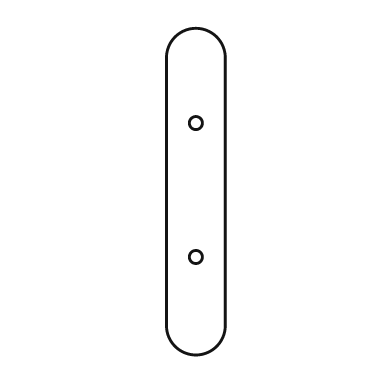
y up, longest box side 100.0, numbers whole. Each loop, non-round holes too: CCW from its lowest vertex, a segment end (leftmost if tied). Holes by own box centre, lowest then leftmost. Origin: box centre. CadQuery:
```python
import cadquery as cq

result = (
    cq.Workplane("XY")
    .moveTo(-9.0, -41.0)
    .threePointArc((0.0, -50.0), (9.0, -41.0))
    .lineTo(9.0, 41.0)
    .threePointArc((0.0, 50.0), (-9.0, 41.0))
    .close()
    .moveTo(0.0, -20.0)
    .circle(2.0)
    .moveTo(0.0, 21.0)
    .circle(2.0)
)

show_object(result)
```